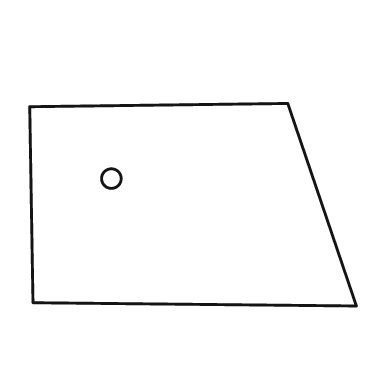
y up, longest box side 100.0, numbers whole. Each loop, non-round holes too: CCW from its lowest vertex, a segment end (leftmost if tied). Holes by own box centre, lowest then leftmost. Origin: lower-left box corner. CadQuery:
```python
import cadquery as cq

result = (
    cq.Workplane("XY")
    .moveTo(100.0, 0.0)
    .lineTo(79.0, 62.0)
    .lineTo(0.0, 61.0)
    .lineTo(1.0, 1.0)
    .close()
    .moveTo(25.0, 39.0)
    .circle(3.0)
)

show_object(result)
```